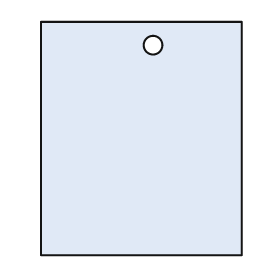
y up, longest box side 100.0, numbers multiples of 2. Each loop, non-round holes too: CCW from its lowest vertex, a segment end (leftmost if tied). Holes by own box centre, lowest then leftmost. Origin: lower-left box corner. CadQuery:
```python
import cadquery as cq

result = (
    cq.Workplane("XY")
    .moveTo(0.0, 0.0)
    .lineTo(86.0, 0.0)
    .lineTo(86.0, 100.0)
    .lineTo(0.0, 100.0)
    .close()
    .moveTo(48.0, 90.0)
    .circle(4.0)
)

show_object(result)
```